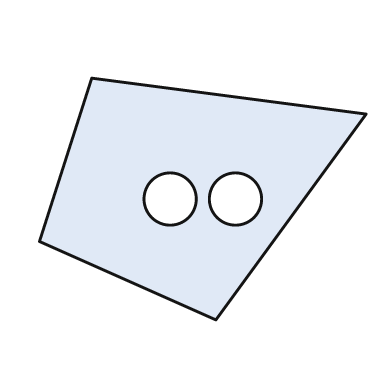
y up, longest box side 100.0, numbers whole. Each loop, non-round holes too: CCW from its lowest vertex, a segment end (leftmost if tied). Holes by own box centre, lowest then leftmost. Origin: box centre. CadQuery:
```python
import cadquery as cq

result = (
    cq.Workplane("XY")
    .moveTo(4.0, -37.0)
    .lineTo(50.0, 26.0)
    .lineTo(-34.0, 37.0)
    .lineTo(-50.0, -13.0)
    .close()
    .moveTo(-10.0, 0.0)
    .circle(8.0)
    .moveTo(10.0, 0.0)
    .circle(8.0)
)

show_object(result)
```